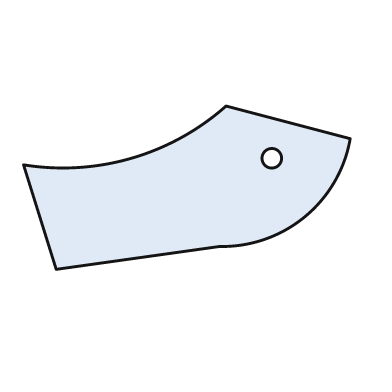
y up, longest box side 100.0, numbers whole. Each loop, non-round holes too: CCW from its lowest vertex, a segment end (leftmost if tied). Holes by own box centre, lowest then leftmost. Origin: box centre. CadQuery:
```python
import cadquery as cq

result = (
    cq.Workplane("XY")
    .moveTo(-40.0, -25.0)
    .lineTo(10.0, -18.0)
    .threePointArc((36.0, -9.0), (50.0, 15.0))
    .lineTo(12.0, 25.0)
    .threePointArc((-17.0, 9.0), (-50.0, 7.0))
    .close()
    .moveTo(26.0, 9.0)
    .circle(3.0)
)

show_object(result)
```